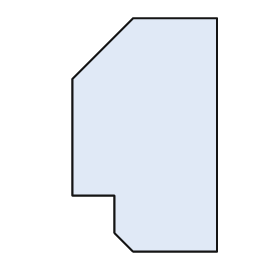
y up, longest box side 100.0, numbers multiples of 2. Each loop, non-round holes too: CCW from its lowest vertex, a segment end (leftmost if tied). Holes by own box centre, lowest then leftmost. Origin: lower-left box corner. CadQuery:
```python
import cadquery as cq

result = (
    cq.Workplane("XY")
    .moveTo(26.0, 0.0)
    .lineTo(62.0, 0.0)
    .lineTo(62.0, 100.0)
    .lineTo(26.0, 100.0)
    .lineTo(0.0, 74.0)
    .lineTo(0.0, 24.0)
    .lineTo(18.0, 24.0)
    .lineTo(18.0, 8.0)
    .close()
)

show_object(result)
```